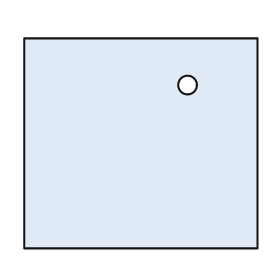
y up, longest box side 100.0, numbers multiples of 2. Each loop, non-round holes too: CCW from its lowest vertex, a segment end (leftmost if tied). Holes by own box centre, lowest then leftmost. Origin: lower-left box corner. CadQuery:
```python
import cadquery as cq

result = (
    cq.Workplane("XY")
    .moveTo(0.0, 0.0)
    .lineTo(100.0, 0.0)
    .lineTo(100.0, 90.0)
    .lineTo(0.0, 90.0)
    .close()
    .moveTo(70.0, 70.0)
    .circle(4.0)
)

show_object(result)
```